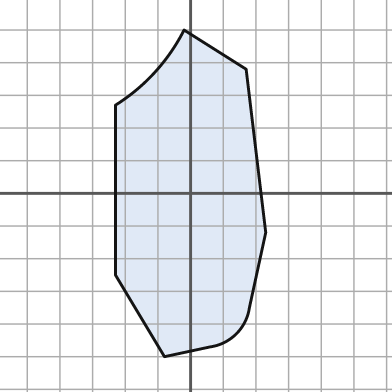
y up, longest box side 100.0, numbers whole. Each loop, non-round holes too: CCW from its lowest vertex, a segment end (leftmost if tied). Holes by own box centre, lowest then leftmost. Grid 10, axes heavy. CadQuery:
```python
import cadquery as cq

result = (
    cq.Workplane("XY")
    .moveTo(-8.0, -50.0)
    .lineTo(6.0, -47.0)
    .threePointArc((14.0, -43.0), (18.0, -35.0))
    .lineTo(23.0, -12.0)
    .lineTo(17.0, 38.0)
    .lineTo(-2.0, 50.0)
    .threePointArc((-11.0, 37.0), (-23.0, 27.0))
    .lineTo(-23.0, -25.0)
    .close()
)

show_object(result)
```